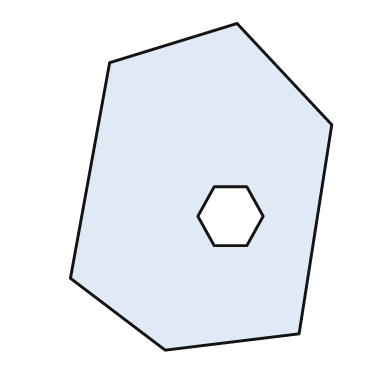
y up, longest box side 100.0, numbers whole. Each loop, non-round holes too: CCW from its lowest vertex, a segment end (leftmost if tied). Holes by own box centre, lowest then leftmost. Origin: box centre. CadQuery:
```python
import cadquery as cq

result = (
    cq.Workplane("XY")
    .moveTo(-11.0, -50.0)
    .lineTo(30.0, -45.0)
    .lineTo(40.0, 19.0)
    .lineTo(11.0, 50.0)
    .lineTo(-28.0, 38.0)
    .lineTo(-40.0, -28.0)
    .close()
    .moveTo(4.0, -18.0)
    .lineTo(14.0, -18.0)
    .lineTo(19.0, -9.0)
    .lineTo(14.0, 0.0)
    .lineTo(4.0, 0.0)
    .lineTo(-1.0, -9.0)
    .close()
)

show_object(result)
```